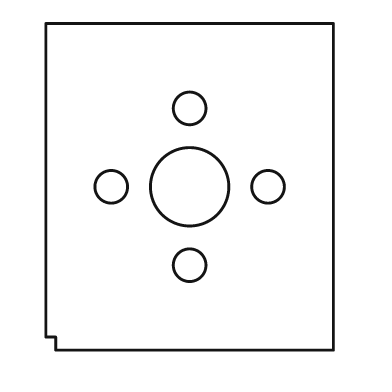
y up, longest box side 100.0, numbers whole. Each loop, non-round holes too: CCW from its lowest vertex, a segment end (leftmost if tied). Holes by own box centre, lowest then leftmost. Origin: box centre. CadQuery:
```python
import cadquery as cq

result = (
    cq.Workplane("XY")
    .moveTo(-41.0, -50.0)
    .lineTo(44.0, -50.0)
    .lineTo(44.0, 50.0)
    .lineTo(-44.0, 50.0)
    .lineTo(-44.0, -46.0)
    .lineTo(-41.0, -46.0)
    .close()
    .moveTo(0.0, -24.0)
    .circle(5.0)
    .moveTo(-24.0, 0.0)
    .circle(5.0)
    .moveTo(0.0, 0.0)
    .circle(12.0)
    .moveTo(24.0, 0.0)
    .circle(5.0)
    .moveTo(0.0, 24.0)
    .circle(5.0)
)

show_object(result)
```